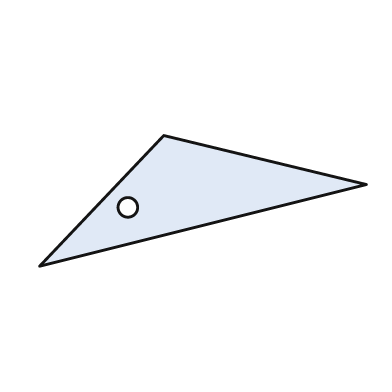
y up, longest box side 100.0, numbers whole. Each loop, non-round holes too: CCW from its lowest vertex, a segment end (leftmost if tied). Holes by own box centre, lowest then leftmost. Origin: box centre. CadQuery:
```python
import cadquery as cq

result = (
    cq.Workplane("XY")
    .moveTo(-50.0, -20.0)
    .lineTo(50.0, 5.0)
    .lineTo(-12.0, 20.0)
    .close()
    .moveTo(-23.0, -2.0)
    .circle(3.0)
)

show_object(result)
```